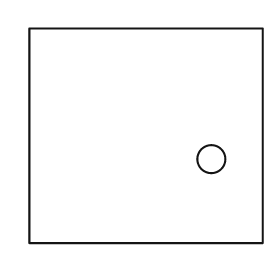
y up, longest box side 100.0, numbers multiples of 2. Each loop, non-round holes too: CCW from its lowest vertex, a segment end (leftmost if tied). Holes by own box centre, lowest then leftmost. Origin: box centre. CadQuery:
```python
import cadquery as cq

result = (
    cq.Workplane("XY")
    .moveTo(-50.0, -46.0)
    .lineTo(50.0, -46.0)
    .lineTo(50.0, 46.0)
    .lineTo(-50.0, 46.0)
    .close()
    .moveTo(28.0, -10.0)
    .circle(6.0)
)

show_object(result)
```